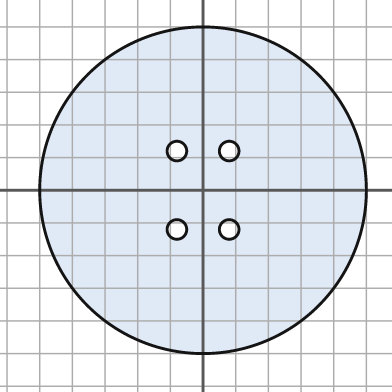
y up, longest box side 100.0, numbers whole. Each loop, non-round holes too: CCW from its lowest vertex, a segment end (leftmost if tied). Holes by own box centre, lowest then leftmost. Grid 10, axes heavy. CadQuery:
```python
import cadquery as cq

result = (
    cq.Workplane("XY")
    .moveTo(0.0, 0.0)
    .circle(50.0)
    .moveTo(-8.0, -12.0)
    .circle(3.0)
    .moveTo(8.0, -12.0)
    .circle(3.0)
    .moveTo(-8.0, 12.0)
    .circle(3.0)
    .moveTo(8.0, 12.0)
    .circle(3.0)
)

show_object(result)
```